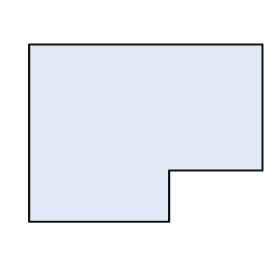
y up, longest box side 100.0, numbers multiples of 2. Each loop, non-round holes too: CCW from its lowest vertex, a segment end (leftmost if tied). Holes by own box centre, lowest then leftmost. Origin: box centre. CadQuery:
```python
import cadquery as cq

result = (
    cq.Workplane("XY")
    .moveTo(-50.0, -38.0)
    .lineTo(10.0, -38.0)
    .lineTo(10.0, -16.0)
    .lineTo(50.0, -16.0)
    .lineTo(50.0, 38.0)
    .lineTo(-50.0, 38.0)
    .close()
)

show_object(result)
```